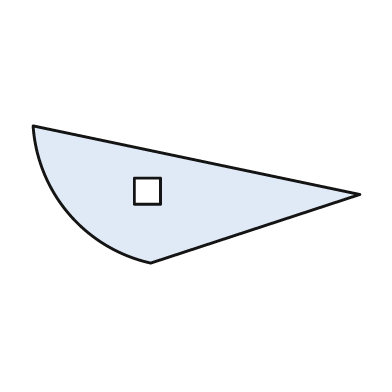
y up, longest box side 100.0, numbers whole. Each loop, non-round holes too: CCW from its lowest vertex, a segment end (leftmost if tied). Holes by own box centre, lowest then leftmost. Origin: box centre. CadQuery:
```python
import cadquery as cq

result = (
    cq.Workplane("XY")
    .moveTo(-14.0, -21.0)
    .lineTo(50.0, 0.0)
    .lineTo(-50.0, 21.0)
    .threePointArc((-39.0, -6.0), (-14.0, -21.0))
    .close()
    .moveTo(-19.0, -3.0)
    .lineTo(-11.0, -3.0)
    .lineTo(-11.0, 5.0)
    .lineTo(-19.0, 5.0)
    .close()
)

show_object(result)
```